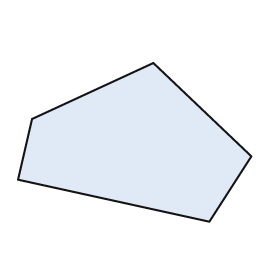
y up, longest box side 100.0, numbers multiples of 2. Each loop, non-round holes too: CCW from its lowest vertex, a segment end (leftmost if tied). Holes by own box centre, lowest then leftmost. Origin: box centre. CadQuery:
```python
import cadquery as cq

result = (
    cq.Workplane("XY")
    .moveTo(32.0, -34.0)
    .lineTo(50.0, -6.0)
    .lineTo(8.0, 34.0)
    .lineTo(-44.0, 10.0)
    .lineTo(-50.0, -16.0)
    .close()
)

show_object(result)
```